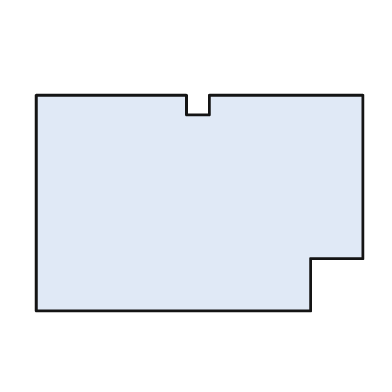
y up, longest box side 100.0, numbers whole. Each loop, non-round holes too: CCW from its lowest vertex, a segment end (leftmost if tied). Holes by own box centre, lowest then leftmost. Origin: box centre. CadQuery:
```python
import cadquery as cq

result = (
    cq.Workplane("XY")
    .moveTo(-50.0, -33.0)
    .lineTo(34.0, -33.0)
    .lineTo(34.0, -17.0)
    .lineTo(50.0, -17.0)
    .lineTo(50.0, 33.0)
    .lineTo(3.0, 33.0)
    .lineTo(3.0, 27.0)
    .lineTo(-4.0, 27.0)
    .lineTo(-4.0, 33.0)
    .lineTo(-50.0, 33.0)
    .close()
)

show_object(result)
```